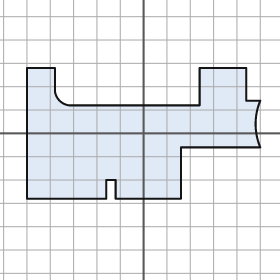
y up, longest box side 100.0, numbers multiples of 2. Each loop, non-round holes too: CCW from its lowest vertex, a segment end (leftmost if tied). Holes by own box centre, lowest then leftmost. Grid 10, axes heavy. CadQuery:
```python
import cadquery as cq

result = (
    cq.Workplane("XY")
    .moveTo(-50.0, -28.0)
    .lineTo(-16.0, -28.0)
    .lineTo(-16.0, -20.0)
    .lineTo(-12.0, -20.0)
    .lineTo(-12.0, -28.0)
    .lineTo(16.0, -28.0)
    .lineTo(16.0, -6.0)
    .lineTo(50.0, -6.0)
    .threePointArc((48.0, 4.0), (50.0, 14.0))
    .lineTo(44.0, 14.0)
    .lineTo(44.0, 28.0)
    .lineTo(24.0, 28.0)
    .lineTo(24.0, 12.0)
    .lineTo(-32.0, 12.0)
    .threePointArc((-36.0, 14.0), (-38.0, 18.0))
    .lineTo(-38.0, 28.0)
    .lineTo(-50.0, 28.0)
    .close()
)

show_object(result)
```